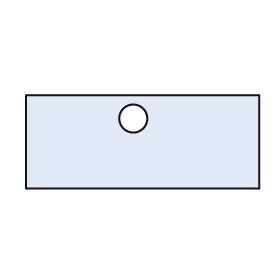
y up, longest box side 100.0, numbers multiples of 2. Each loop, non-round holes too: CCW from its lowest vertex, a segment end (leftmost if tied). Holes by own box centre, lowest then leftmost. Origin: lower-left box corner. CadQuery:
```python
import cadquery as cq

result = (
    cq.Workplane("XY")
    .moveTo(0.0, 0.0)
    .lineTo(100.0, 0.0)
    .lineTo(100.0, 40.0)
    .lineTo(0.0, 40.0)
    .close()
    .moveTo(46.0, 30.0)
    .circle(6.0)
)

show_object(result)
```